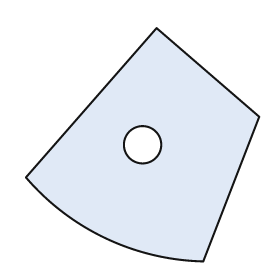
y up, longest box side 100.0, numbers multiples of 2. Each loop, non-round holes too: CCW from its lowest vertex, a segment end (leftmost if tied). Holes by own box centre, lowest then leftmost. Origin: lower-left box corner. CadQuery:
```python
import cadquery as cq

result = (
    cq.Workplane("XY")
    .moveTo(76.0, 0.0)
    .lineTo(100.0, 62.0)
    .lineTo(56.0, 100.0)
    .lineTo(0.0, 36.0)
    .threePointArc((34.0, 10.0), (76.0, 0.0))
    .close()
    .moveTo(50.0, 50.0)
    .circle(8.0)
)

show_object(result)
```